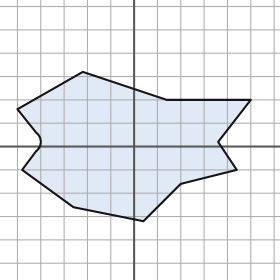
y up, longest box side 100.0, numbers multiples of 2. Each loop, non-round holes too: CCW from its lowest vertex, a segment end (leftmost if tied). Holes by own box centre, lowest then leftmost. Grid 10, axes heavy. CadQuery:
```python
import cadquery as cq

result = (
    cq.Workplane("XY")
    .moveTo(4.0, -32.0)
    .lineTo(20.0, -16.0)
    .lineTo(44.0, -10.0)
    .lineTo(36.0, 2.0)
    .lineTo(50.0, 20.0)
    .lineTo(14.0, 20.0)
    .lineTo(-22.0, 32.0)
    .lineTo(-50.0, 16.0)
    .lineTo(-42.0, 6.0)
    .threePointArc((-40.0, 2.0), (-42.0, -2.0))
    .lineTo(-48.0, -10.0)
    .lineTo(-26.0, -26.0)
    .close()
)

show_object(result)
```